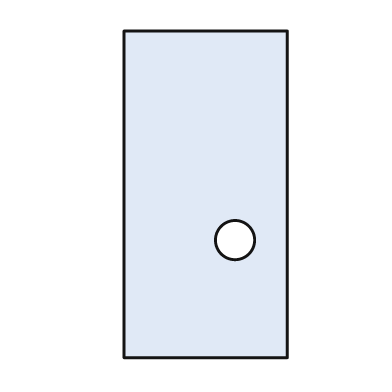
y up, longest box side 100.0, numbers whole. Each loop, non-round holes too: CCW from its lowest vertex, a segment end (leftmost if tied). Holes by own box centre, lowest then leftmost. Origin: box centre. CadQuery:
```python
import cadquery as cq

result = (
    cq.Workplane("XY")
    .moveTo(-25.0, -50.0)
    .lineTo(25.0, -50.0)
    .lineTo(25.0, 50.0)
    .lineTo(-25.0, 50.0)
    .close()
    .moveTo(9.0, -14.0)
    .circle(6.0)
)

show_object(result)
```